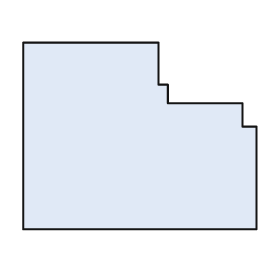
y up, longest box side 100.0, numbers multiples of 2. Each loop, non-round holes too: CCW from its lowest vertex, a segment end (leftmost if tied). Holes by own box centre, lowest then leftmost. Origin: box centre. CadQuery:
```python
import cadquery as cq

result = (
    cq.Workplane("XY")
    .moveTo(-50.0, -40.0)
    .lineTo(50.0, -40.0)
    .lineTo(50.0, 4.0)
    .lineTo(44.0, 4.0)
    .lineTo(44.0, 14.0)
    .lineTo(12.0, 14.0)
    .lineTo(12.0, 22.0)
    .lineTo(8.0, 22.0)
    .lineTo(8.0, 40.0)
    .lineTo(-50.0, 40.0)
    .close()
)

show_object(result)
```